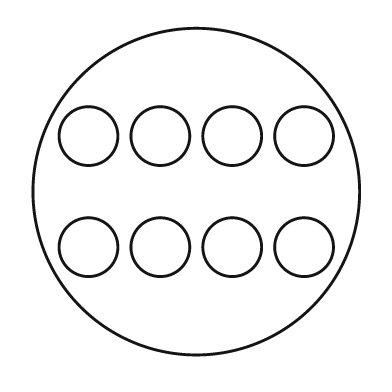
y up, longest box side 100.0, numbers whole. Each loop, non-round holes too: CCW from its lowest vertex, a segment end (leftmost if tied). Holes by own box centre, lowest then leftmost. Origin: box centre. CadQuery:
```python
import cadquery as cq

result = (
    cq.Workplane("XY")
    .moveTo(0.0, 0.0)
    .circle(50.0)
    .moveTo(-33.0, -17.0)
    .circle(9.0)
    .moveTo(-11.0, -17.0)
    .circle(9.0)
    .moveTo(11.0, -17.0)
    .circle(9.0)
    .moveTo(33.0, -17.0)
    .circle(9.0)
    .moveTo(-33.0, 17.0)
    .circle(9.0)
    .moveTo(-11.0, 17.0)
    .circle(9.0)
    .moveTo(11.0, 17.0)
    .circle(9.0)
    .moveTo(33.0, 17.0)
    .circle(9.0)
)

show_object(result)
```